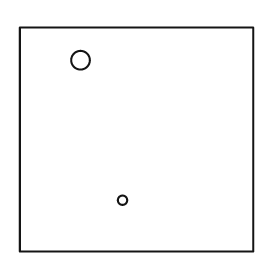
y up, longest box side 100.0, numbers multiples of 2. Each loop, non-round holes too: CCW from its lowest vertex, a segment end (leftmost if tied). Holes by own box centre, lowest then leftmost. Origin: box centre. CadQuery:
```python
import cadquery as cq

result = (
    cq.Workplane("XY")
    .moveTo(-50.0, -48.0)
    .lineTo(50.0, -48.0)
    .lineTo(50.0, 48.0)
    .lineTo(-50.0, 48.0)
    .close()
    .moveTo(-6.0, -26.0)
    .circle(2.0)
    .moveTo(-24.0, 34.0)
    .circle(4.0)
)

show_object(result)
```